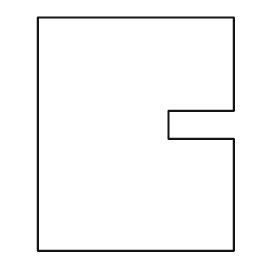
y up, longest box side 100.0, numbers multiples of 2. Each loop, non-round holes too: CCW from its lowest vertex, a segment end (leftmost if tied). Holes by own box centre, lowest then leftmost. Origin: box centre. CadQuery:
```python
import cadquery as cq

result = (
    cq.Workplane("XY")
    .moveTo(-42.0, -50.0)
    .lineTo(42.0, -50.0)
    .lineTo(42.0, -2.0)
    .lineTo(14.0, -2.0)
    .lineTo(14.0, 10.0)
    .lineTo(42.0, 10.0)
    .lineTo(42.0, 50.0)
    .lineTo(-42.0, 50.0)
    .close()
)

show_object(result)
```